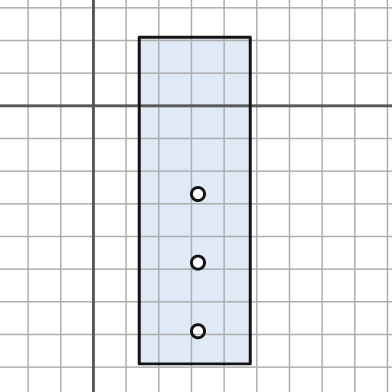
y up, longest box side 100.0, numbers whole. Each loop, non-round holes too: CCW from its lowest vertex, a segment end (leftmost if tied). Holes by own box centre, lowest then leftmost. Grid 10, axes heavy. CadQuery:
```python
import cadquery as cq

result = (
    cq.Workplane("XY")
    .moveTo(14.0, -79.0)
    .lineTo(48.0, -79.0)
    .lineTo(48.0, 21.0)
    .lineTo(14.0, 21.0)
    .close()
    .moveTo(32.0, -69.0)
    .circle(2.0)
    .moveTo(32.0, -48.0)
    .circle(2.0)
    .moveTo(32.0, -27.0)
    .circle(2.0)
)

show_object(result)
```